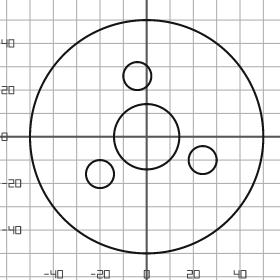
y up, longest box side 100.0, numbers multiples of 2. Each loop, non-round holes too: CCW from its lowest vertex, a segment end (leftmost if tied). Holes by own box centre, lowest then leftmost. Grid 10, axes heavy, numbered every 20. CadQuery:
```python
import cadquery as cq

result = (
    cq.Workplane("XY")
    .moveTo(0.0, 0.0)
    .circle(50.0)
    .moveTo(-20.0, -16.0)
    .circle(6.0)
    .moveTo(24.0, -10.0)
    .circle(6.0)
    .moveTo(0.0, 0.0)
    .circle(14.0)
    .moveTo(-4.0, 26.0)
    .circle(6.0)
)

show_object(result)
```